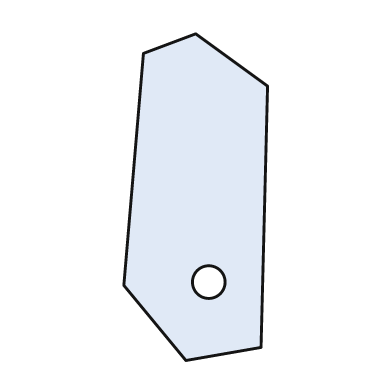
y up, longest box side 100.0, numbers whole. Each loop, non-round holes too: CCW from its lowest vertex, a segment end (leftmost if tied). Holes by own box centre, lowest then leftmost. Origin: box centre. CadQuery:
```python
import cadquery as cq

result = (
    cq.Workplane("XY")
    .moveTo(-3.0, -50.0)
    .lineTo(20.0, -46.0)
    .lineTo(22.0, 34.0)
    .lineTo(0.0, 50.0)
    .lineTo(-16.0, 44.0)
    .lineTo(-22.0, -27.0)
    .close()
    .moveTo(4.0, -26.0)
    .circle(5.0)
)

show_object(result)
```